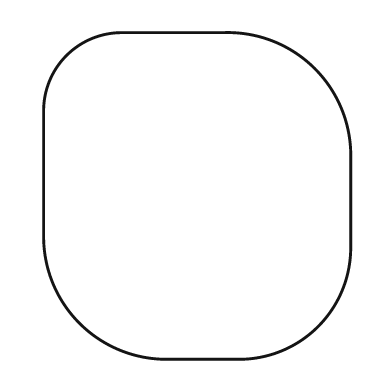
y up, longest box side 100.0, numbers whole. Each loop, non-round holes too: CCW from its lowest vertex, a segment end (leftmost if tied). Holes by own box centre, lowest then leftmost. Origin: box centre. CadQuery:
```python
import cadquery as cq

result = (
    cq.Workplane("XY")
    .moveTo(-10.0, -50.0)
    .lineTo(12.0, -50.0)
    .threePointArc((37.0, -40.0), (47.0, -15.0))
    .lineTo(47.0, 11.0)
    .threePointArc((36.0, 39.0), (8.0, 50.0))
    .lineTo(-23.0, 50.0)
    .threePointArc((-40.0, 43.0), (-47.0, 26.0))
    .lineTo(-47.0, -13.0)
    .threePointArc((-36.0, -39.0), (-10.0, -50.0))
    .close()
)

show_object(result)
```